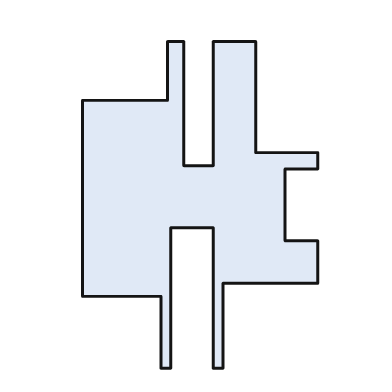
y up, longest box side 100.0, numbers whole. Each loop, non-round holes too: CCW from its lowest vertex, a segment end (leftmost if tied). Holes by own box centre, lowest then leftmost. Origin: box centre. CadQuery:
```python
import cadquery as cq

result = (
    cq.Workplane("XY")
    .moveTo(-12.0, -50.0)
    .lineTo(-9.0, -50.0)
    .lineTo(-9.0, -7.0)
    .lineTo(4.0, -7.0)
    .lineTo(4.0, -50.0)
    .lineTo(7.0, -50.0)
    .lineTo(7.0, -24.0)
    .lineTo(36.0, -24.0)
    .lineTo(36.0, -11.0)
    .lineTo(26.0, -11.0)
    .lineTo(26.0, 11.0)
    .lineTo(36.0, 11.0)
    .lineTo(36.0, 16.0)
    .lineTo(17.0, 16.0)
    .lineTo(17.0, 50.0)
    .lineTo(4.0, 50.0)
    .lineTo(4.0, 12.0)
    .lineTo(-5.0, 12.0)
    .lineTo(-5.0, 50.0)
    .lineTo(-10.0, 50.0)
    .lineTo(-10.0, 32.0)
    .lineTo(-36.0, 32.0)
    .lineTo(-36.0, -28.0)
    .lineTo(-12.0, -28.0)
    .close()
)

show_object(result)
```